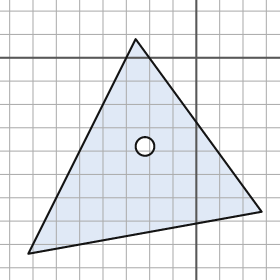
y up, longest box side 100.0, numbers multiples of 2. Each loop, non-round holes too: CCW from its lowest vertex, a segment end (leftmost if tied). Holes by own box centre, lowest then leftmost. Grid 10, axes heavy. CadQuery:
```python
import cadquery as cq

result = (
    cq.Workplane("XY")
    .moveTo(-72.0, -84.0)
    .lineTo(28.0, -66.0)
    .lineTo(-26.0, 8.0)
    .close()
    .moveTo(-22.0, -38.0)
    .circle(4.0)
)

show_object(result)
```